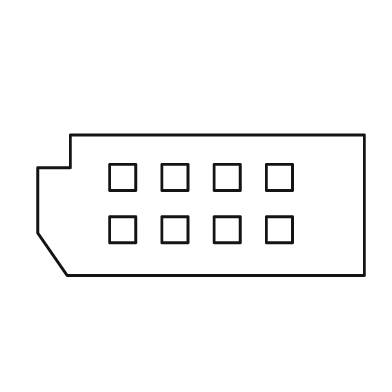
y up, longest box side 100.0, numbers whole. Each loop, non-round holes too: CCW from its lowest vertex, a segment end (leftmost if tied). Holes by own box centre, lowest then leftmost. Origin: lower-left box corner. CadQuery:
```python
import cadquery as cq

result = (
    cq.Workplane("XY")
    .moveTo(9.0, 0.0)
    .lineTo(100.0, 0.0)
    .lineTo(100.0, 43.0)
    .lineTo(10.0, 43.0)
    .lineTo(10.0, 33.0)
    .lineTo(0.0, 33.0)
    .lineTo(0.0, 13.0)
    .close()
    .moveTo(22.0, 10.0)
    .lineTo(30.0, 10.0)
    .lineTo(30.0, 18.0)
    .lineTo(22.0, 18.0)
    .close()
    .moveTo(38.0, 10.0)
    .lineTo(46.0, 10.0)
    .lineTo(46.0, 18.0)
    .lineTo(38.0, 18.0)
    .close()
    .moveTo(54.0, 10.0)
    .lineTo(62.0, 10.0)
    .lineTo(62.0, 18.0)
    .lineTo(54.0, 18.0)
    .close()
    .moveTo(70.0, 10.0)
    .lineTo(78.0, 10.0)
    .lineTo(78.0, 18.0)
    .lineTo(70.0, 18.0)
    .close()
    .moveTo(22.0, 26.0)
    .lineTo(30.0, 26.0)
    .lineTo(30.0, 34.0)
    .lineTo(22.0, 34.0)
    .close()
    .moveTo(38.0, 26.0)
    .lineTo(46.0, 26.0)
    .lineTo(46.0, 34.0)
    .lineTo(38.0, 34.0)
    .close()
    .moveTo(54.0, 26.0)
    .lineTo(62.0, 26.0)
    .lineTo(62.0, 34.0)
    .lineTo(54.0, 34.0)
    .close()
    .moveTo(70.0, 26.0)
    .lineTo(78.0, 26.0)
    .lineTo(78.0, 34.0)
    .lineTo(70.0, 34.0)
    .close()
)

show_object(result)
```